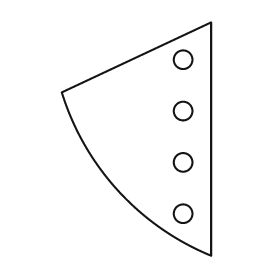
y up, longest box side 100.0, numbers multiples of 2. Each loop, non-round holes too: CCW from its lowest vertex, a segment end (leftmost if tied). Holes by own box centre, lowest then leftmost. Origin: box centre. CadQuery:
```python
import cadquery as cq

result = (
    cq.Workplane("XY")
    .moveTo(32.0, -50.0)
    .lineTo(32.0, 50.0)
    .lineTo(-32.0, 20.0)
    .threePointArc((-8.0, -22.0), (32.0, -50.0))
    .close()
    .moveTo(20.0, -32.0)
    .circle(4.0)
    .moveTo(20.0, -10.0)
    .circle(4.0)
    .moveTo(20.0, 12.0)
    .circle(4.0)
    .moveTo(20.0, 34.0)
    .circle(4.0)
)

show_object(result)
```